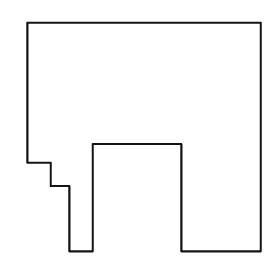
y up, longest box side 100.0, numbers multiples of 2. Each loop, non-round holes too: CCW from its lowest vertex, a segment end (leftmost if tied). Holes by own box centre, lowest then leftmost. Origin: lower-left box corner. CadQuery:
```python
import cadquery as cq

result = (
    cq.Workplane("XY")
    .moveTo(18.0, 0.0)
    .lineTo(28.0, 0.0)
    .lineTo(28.0, 46.0)
    .lineTo(66.0, 46.0)
    .lineTo(66.0, 0.0)
    .lineTo(100.0, 0.0)
    .lineTo(100.0, 98.0)
    .lineTo(0.0, 98.0)
    .lineTo(0.0, 38.0)
    .lineTo(10.0, 38.0)
    .lineTo(10.0, 28.0)
    .lineTo(18.0, 28.0)
    .close()
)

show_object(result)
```